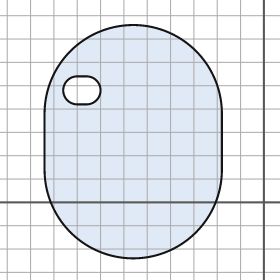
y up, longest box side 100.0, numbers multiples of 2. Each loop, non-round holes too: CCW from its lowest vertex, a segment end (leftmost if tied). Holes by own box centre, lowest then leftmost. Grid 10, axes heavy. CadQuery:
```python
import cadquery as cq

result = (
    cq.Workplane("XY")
    .moveTo(-94.0, 14.0)
    .threePointArc((-56.0, -24.0), (-18.0, 14.0))
    .lineTo(-18.0, 38.0)
    .threePointArc((-56.0, 76.0), (-94.0, 38.0))
    .close()
    .moveTo(-80.0, 42.0)
    .lineTo(-76.0, 42.0)
    .threePointArc((-70.0, 48.0), (-76.0, 54.0))
    .lineTo(-80.0, 54.0)
    .threePointArc((-86.0, 48.0), (-80.0, 42.0))
    .close()
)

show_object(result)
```